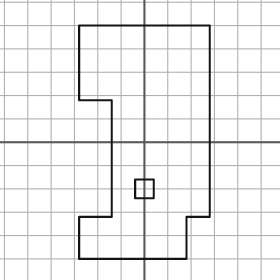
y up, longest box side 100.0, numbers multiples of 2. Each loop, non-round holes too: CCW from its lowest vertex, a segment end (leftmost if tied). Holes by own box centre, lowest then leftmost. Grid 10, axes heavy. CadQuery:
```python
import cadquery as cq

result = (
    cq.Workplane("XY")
    .moveTo(-28.0, -50.0)
    .lineTo(18.0, -50.0)
    .lineTo(18.0, -32.0)
    .lineTo(28.0, -32.0)
    .lineTo(28.0, 50.0)
    .lineTo(-28.0, 50.0)
    .lineTo(-28.0, 18.0)
    .lineTo(-14.0, 18.0)
    .lineTo(-14.0, -32.0)
    .lineTo(-28.0, -32.0)
    .close()
    .moveTo(-4.0, -24.0)
    .lineTo(4.0, -24.0)
    .lineTo(4.0, -16.0)
    .lineTo(-4.0, -16.0)
    .close()
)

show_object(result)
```